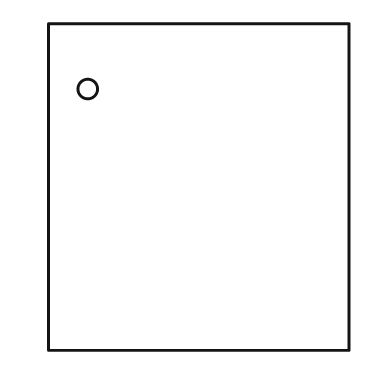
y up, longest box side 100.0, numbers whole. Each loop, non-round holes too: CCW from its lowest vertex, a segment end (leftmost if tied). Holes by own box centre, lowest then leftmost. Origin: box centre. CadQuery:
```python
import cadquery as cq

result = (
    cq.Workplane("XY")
    .moveTo(-46.0, -50.0)
    .lineTo(46.0, -50.0)
    .lineTo(46.0, 50.0)
    .lineTo(-46.0, 50.0)
    .close()
    .moveTo(-34.0, 30.0)
    .circle(3.0)
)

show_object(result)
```